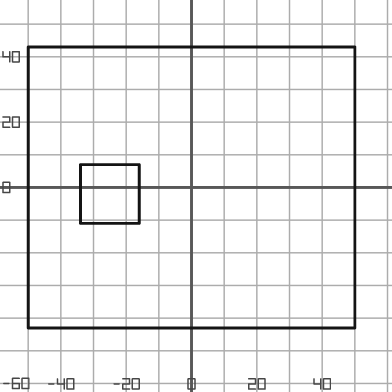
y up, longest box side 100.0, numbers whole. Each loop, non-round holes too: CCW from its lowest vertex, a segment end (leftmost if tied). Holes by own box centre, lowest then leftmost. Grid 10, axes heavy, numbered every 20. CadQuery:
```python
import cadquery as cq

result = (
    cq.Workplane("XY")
    .moveTo(-50.0, -43.0)
    .lineTo(50.0, -43.0)
    .lineTo(50.0, 43.0)
    .lineTo(-50.0, 43.0)
    .close()
    .moveTo(-34.0, -11.0)
    .lineTo(-16.0, -11.0)
    .lineTo(-16.0, 7.0)
    .lineTo(-34.0, 7.0)
    .close()
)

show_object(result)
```